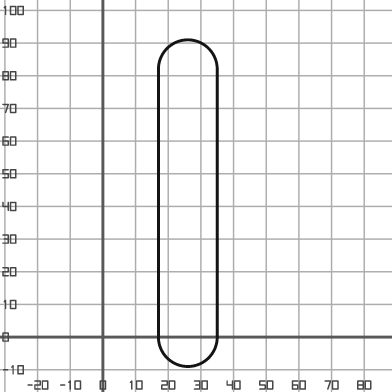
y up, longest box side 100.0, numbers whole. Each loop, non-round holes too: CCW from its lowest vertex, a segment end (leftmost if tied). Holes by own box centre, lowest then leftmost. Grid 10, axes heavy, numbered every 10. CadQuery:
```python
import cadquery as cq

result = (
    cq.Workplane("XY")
    .moveTo(17.0, 0.0)
    .threePointArc((26.0, -9.0), (35.0, 0.0))
    .lineTo(35.0, 82.0)
    .threePointArc((26.0, 91.0), (17.0, 82.0))
    .close()
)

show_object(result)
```